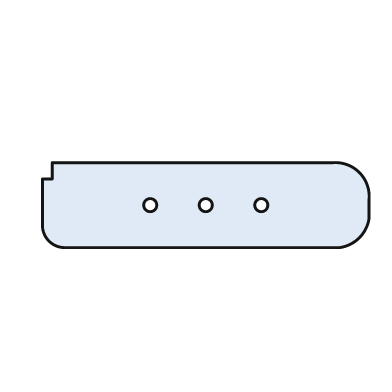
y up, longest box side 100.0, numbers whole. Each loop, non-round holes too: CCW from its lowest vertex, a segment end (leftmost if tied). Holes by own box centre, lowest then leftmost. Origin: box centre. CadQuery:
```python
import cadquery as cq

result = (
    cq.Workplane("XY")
    .moveTo(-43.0, -13.0)
    .lineTo(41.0, -13.0)
    .threePointArc((47.0, -10.0), (50.0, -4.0))
    .lineTo(50.0, 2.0)
    .threePointArc((47.0, 10.0), (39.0, 13.0))
    .lineTo(-47.0, 13.0)
    .lineTo(-47.0, 8.0)
    .lineTo(-50.0, 8.0)
    .lineTo(-50.0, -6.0)
    .threePointArc((-48.0, -11.0), (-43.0, -13.0))
    .close()
    .moveTo(-17.0, 0.0)
    .circle(2.0)
    .moveTo(0.0, 0.0)
    .circle(2.0)
    .moveTo(17.0, 0.0)
    .circle(2.0)
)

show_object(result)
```